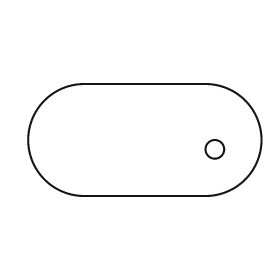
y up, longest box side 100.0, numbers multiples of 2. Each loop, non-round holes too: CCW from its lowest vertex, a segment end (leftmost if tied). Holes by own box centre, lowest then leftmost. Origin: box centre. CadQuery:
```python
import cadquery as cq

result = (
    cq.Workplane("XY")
    .moveTo(-26.0, -24.0)
    .lineTo(26.0, -24.0)
    .threePointArc((50.0, 0.0), (26.0, 24.0))
    .lineTo(-26.0, 24.0)
    .threePointArc((-50.0, 0.0), (-26.0, -24.0))
    .close()
    .moveTo(30.0, -4.0)
    .circle(4.0)
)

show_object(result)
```